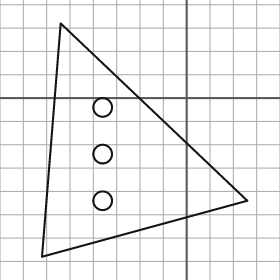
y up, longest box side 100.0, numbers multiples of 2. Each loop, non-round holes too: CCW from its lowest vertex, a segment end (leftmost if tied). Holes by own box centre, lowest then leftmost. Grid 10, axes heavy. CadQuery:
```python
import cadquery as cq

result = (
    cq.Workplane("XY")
    .moveTo(-62.0, -68.0)
    .lineTo(26.0, -44.0)
    .lineTo(-54.0, 32.0)
    .close()
    .moveTo(-36.0, -44.0)
    .circle(4.0)
    .moveTo(-36.0, -24.0)
    .circle(4.0)
    .moveTo(-36.0, -4.0)
    .circle(4.0)
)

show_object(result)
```